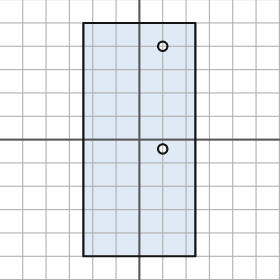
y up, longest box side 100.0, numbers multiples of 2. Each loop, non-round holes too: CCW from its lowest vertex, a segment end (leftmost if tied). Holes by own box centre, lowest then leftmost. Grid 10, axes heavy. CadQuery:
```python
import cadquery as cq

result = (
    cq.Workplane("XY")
    .moveTo(-24.0, -50.0)
    .lineTo(24.0, -50.0)
    .lineTo(24.0, 50.0)
    .lineTo(-24.0, 50.0)
    .close()
    .moveTo(10.0, -4.0)
    .circle(2.0)
    .moveTo(10.0, 40.0)
    .circle(2.0)
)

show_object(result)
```